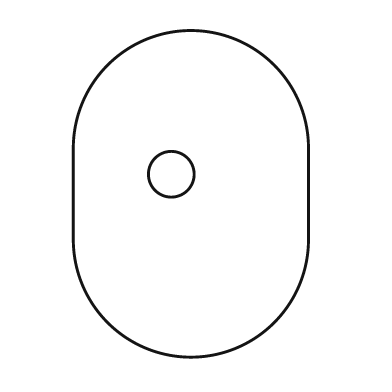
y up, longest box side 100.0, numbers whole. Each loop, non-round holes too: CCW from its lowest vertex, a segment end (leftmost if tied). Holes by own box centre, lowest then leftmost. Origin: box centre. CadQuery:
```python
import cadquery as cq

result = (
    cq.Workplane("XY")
    .moveTo(-36.0, -14.0)
    .threePointArc((0.0, -50.0), (36.0, -14.0))
    .lineTo(36.0, 14.0)
    .threePointArc((0.0, 50.0), (-36.0, 14.0))
    .close()
    .moveTo(-6.0, 6.0)
    .circle(7.0)
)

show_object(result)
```